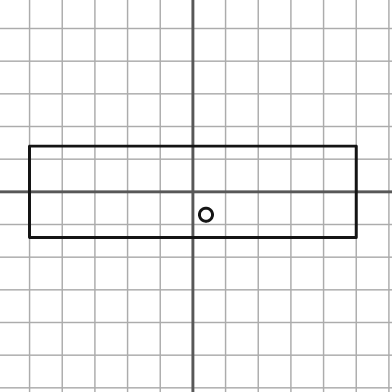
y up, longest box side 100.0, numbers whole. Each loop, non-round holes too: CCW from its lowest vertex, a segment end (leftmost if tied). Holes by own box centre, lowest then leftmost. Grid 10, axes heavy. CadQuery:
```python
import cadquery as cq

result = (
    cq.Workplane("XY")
    .moveTo(-50.0, -14.0)
    .lineTo(50.0, -14.0)
    .lineTo(50.0, 14.0)
    .lineTo(-50.0, 14.0)
    .close()
    .moveTo(4.0, -7.0)
    .circle(2.0)
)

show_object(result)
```